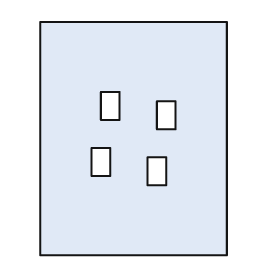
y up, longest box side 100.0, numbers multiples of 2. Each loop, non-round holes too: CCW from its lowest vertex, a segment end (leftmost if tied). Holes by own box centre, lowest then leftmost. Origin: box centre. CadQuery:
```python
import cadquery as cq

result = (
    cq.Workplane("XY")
    .moveTo(-40.0, -50.0)
    .lineTo(40.0, -50.0)
    .lineTo(40.0, 50.0)
    .lineTo(-40.0, 50.0)
    .close()
    .moveTo(6.0, -20.0)
    .lineTo(14.0, -20.0)
    .lineTo(14.0, -8.0)
    .lineTo(6.0, -8.0)
    .close()
    .moveTo(-18.0, -16.0)
    .lineTo(-10.0, -16.0)
    .lineTo(-10.0, -4.0)
    .lineTo(-18.0, -4.0)
    .close()
    .moveTo(10.0, 4.0)
    .lineTo(18.0, 4.0)
    .lineTo(18.0, 16.0)
    .lineTo(10.0, 16.0)
    .close()
    .moveTo(-14.0, 8.0)
    .lineTo(-6.0, 8.0)
    .lineTo(-6.0, 20.0)
    .lineTo(-14.0, 20.0)
    .close()
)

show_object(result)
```